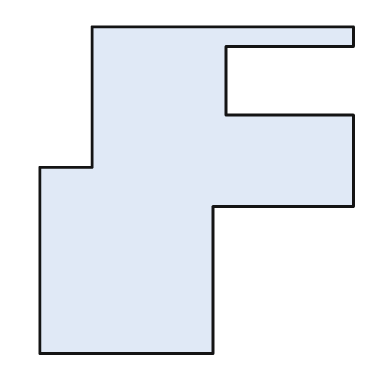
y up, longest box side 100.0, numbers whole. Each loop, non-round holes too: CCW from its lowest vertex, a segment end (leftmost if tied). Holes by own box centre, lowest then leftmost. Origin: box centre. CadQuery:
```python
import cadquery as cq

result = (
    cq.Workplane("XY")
    .moveTo(-48.0, -50.0)
    .lineTo(5.0, -50.0)
    .lineTo(5.0, -5.0)
    .lineTo(48.0, -5.0)
    .lineTo(48.0, 23.0)
    .lineTo(9.0, 23.0)
    .lineTo(9.0, 44.0)
    .lineTo(48.0, 44.0)
    .lineTo(48.0, 50.0)
    .lineTo(-32.0, 50.0)
    .lineTo(-32.0, 7.0)
    .lineTo(-48.0, 7.0)
    .close()
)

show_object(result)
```